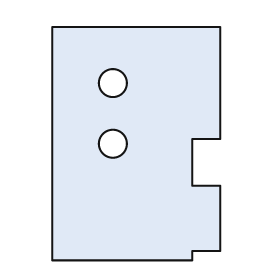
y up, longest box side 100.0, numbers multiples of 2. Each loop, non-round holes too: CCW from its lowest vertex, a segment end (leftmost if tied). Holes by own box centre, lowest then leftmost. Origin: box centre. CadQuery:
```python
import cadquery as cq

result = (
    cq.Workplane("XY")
    .moveTo(-36.0, -50.0)
    .lineTo(24.0, -50.0)
    .lineTo(24.0, -46.0)
    .lineTo(36.0, -46.0)
    .lineTo(36.0, -18.0)
    .lineTo(24.0, -18.0)
    .lineTo(24.0, 2.0)
    .lineTo(36.0, 2.0)
    .lineTo(36.0, 50.0)
    .lineTo(-36.0, 50.0)
    .close()
    .moveTo(-10.0, 0.0)
    .circle(6.0)
    .moveTo(-10.0, 26.0)
    .circle(6.0)
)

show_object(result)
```